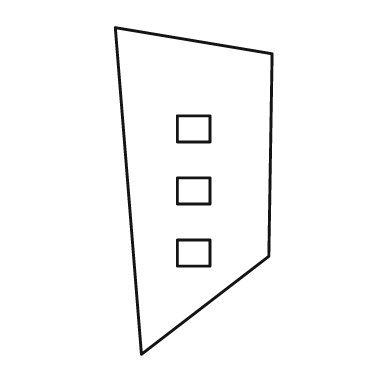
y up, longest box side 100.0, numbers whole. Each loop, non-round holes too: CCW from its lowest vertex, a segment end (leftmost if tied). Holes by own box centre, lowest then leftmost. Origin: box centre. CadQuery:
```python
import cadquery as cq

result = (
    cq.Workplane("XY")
    .moveTo(-16.0, -50.0)
    .lineTo(23.0, -20.0)
    .lineTo(24.0, 42.0)
    .lineTo(-24.0, 50.0)
    .close()
    .moveTo(-5.0, -23.0)
    .lineTo(5.0, -23.0)
    .lineTo(5.0, -15.0)
    .lineTo(-5.0, -15.0)
    .close()
    .moveTo(-5.0, -4.0)
    .lineTo(5.0, -4.0)
    .lineTo(5.0, 4.0)
    .lineTo(-5.0, 4.0)
    .close()
    .moveTo(-5.0, 15.0)
    .lineTo(5.0, 15.0)
    .lineTo(5.0, 23.0)
    .lineTo(-5.0, 23.0)
    .close()
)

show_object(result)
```